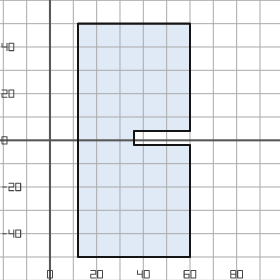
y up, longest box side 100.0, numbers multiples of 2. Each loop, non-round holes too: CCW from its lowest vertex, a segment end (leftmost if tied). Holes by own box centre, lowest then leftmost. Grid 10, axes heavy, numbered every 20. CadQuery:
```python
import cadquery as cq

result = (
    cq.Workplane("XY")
    .moveTo(12.0, -50.0)
    .lineTo(60.0, -50.0)
    .lineTo(60.0, -2.0)
    .lineTo(36.0, -2.0)
    .lineTo(36.0, 4.0)
    .lineTo(60.0, 4.0)
    .lineTo(60.0, 50.0)
    .lineTo(12.0, 50.0)
    .close()
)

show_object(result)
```